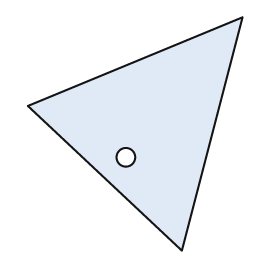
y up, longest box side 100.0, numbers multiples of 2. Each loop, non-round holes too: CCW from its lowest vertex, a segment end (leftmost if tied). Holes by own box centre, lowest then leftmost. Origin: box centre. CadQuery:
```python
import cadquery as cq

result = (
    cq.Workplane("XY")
    .moveTo(20.0, -50.0)
    .lineTo(46.0, 50.0)
    .lineTo(-46.0, 12.0)
    .close()
    .moveTo(-4.0, -10.0)
    .circle(4.0)
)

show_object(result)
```